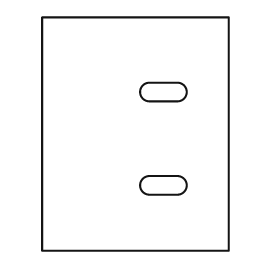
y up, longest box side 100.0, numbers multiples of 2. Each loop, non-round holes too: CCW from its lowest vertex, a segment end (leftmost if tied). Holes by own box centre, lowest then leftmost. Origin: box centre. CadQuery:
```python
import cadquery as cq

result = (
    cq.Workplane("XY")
    .moveTo(-40.0, -50.0)
    .lineTo(40.0, -50.0)
    .lineTo(40.0, 50.0)
    .lineTo(-40.0, 50.0)
    .close()
    .moveTo(6.0, -26.0)
    .lineTo(18.0, -26.0)
    .threePointArc((22.0, -22.0), (18.0, -18.0))
    .lineTo(6.0, -18.0)
    .threePointArc((2.0, -22.0), (6.0, -26.0))
    .close()
    .moveTo(6.0, 14.0)
    .lineTo(18.0, 14.0)
    .threePointArc((22.0, 18.0), (18.0, 22.0))
    .lineTo(6.0, 22.0)
    .threePointArc((2.0, 18.0), (6.0, 14.0))
    .close()
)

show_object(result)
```